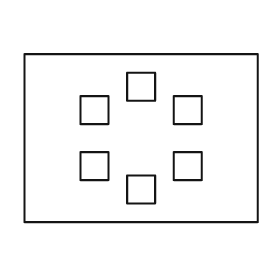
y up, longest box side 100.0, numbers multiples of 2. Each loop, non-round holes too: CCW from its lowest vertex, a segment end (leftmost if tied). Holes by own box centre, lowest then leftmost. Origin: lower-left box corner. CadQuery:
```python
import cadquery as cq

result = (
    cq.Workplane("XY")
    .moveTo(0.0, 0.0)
    .lineTo(100.0, 0.0)
    .lineTo(100.0, 72.0)
    .lineTo(0.0, 72.0)
    .close()
    .moveTo(44.0, 8.0)
    .lineTo(56.0, 8.0)
    .lineTo(56.0, 20.0)
    .lineTo(44.0, 20.0)
    .close()
    .moveTo(24.0, 18.0)
    .lineTo(36.0, 18.0)
    .lineTo(36.0, 30.0)
    .lineTo(24.0, 30.0)
    .close()
    .moveTo(64.0, 18.0)
    .lineTo(76.0, 18.0)
    .lineTo(76.0, 30.0)
    .lineTo(64.0, 30.0)
    .close()
    .moveTo(24.0, 42.0)
    .lineTo(36.0, 42.0)
    .lineTo(36.0, 54.0)
    .lineTo(24.0, 54.0)
    .close()
    .moveTo(64.0, 42.0)
    .lineTo(76.0, 42.0)
    .lineTo(76.0, 54.0)
    .lineTo(64.0, 54.0)
    .close()
    .moveTo(44.0, 52.0)
    .lineTo(56.0, 52.0)
    .lineTo(56.0, 64.0)
    .lineTo(44.0, 64.0)
    .close()
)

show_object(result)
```